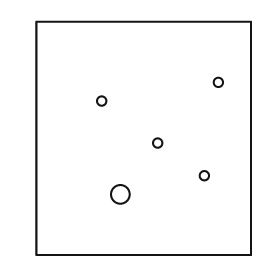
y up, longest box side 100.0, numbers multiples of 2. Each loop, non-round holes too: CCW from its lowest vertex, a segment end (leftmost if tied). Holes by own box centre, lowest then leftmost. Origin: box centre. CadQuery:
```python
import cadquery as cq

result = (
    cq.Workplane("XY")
    .moveTo(-46.0, -50.0)
    .lineTo(46.0, -50.0)
    .lineTo(46.0, 50.0)
    .lineTo(-46.0, 50.0)
    .close()
    .moveTo(-10.0, -24.0)
    .circle(4.0)
    .moveTo(26.0, -16.0)
    .circle(2.0)
    .moveTo(6.0, -2.0)
    .circle(2.0)
    .moveTo(-18.0, 16.0)
    .circle(2.0)
    .moveTo(32.0, 24.0)
    .circle(2.0)
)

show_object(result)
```